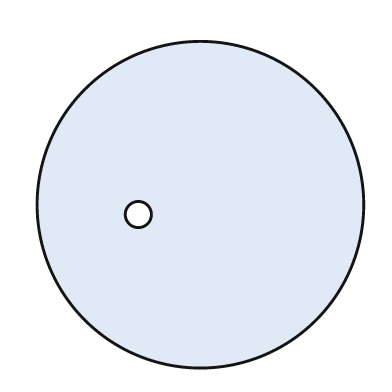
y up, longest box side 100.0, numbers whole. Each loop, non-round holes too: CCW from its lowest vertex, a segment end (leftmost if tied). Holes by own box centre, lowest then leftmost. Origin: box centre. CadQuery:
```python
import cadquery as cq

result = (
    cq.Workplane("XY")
    .moveTo(0.0, 0.0)
    .circle(50.0)
    .moveTo(-19.0, -3.0)
    .circle(4.0)
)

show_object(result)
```